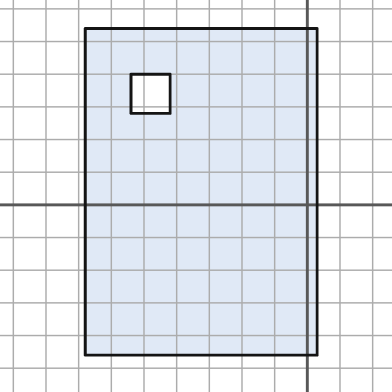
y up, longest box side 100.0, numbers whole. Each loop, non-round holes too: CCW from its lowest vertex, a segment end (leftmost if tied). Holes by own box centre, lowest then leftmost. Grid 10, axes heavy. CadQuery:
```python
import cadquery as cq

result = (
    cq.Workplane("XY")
    .moveTo(-68.0, -46.0)
    .lineTo(3.0, -46.0)
    .lineTo(3.0, 54.0)
    .lineTo(-68.0, 54.0)
    .close()
    .moveTo(-54.0, 28.0)
    .lineTo(-42.0, 28.0)
    .lineTo(-42.0, 40.0)
    .lineTo(-54.0, 40.0)
    .close()
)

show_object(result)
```